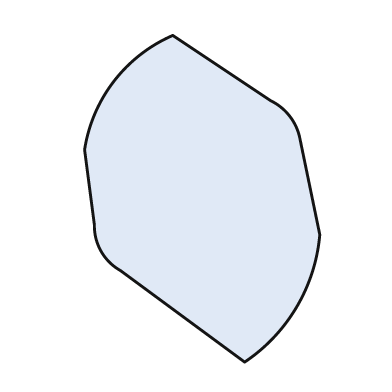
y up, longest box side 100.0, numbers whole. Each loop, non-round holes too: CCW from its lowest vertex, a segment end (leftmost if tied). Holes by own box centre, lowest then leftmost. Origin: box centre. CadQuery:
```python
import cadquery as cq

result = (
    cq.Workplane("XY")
    .moveTo(13.0, -50.0)
    .threePointArc((29.0, -33.0), (36.0, -11.0))
    .lineTo(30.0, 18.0)
    .threePointArc((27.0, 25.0), (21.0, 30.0))
    .lineTo(-9.0, 50.0)
    .threePointArc((-27.0, 36.0), (-36.0, 15.0))
    .lineTo(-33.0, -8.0)
    .threePointArc((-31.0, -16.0), (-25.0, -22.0))
    .close()
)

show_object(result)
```